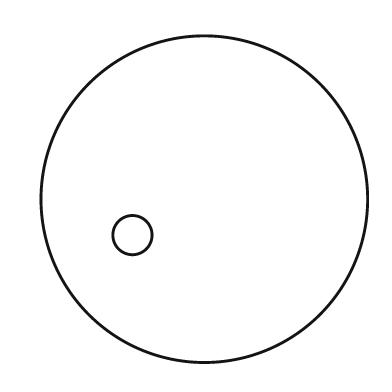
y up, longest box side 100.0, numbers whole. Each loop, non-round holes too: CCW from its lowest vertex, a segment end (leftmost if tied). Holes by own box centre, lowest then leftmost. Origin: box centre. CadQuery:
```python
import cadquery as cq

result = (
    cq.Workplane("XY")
    .moveTo(0.0, 0.0)
    .circle(50.0)
    .moveTo(-22.0, -11.0)
    .circle(6.0)
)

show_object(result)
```